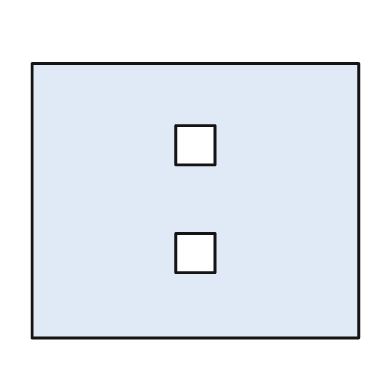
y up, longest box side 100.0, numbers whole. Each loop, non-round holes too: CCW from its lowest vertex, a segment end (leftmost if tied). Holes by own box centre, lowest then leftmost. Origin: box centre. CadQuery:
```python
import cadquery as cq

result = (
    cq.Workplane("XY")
    .moveTo(-50.0, -42.0)
    .lineTo(50.0, -42.0)
    .lineTo(50.0, 42.0)
    .lineTo(-50.0, 42.0)
    .close()
    .moveTo(-6.0, -22.0)
    .lineTo(6.0, -22.0)
    .lineTo(6.0, -10.0)
    .lineTo(-6.0, -10.0)
    .close()
    .moveTo(-6.0, 11.0)
    .lineTo(6.0, 11.0)
    .lineTo(6.0, 23.0)
    .lineTo(-6.0, 23.0)
    .close()
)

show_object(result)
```